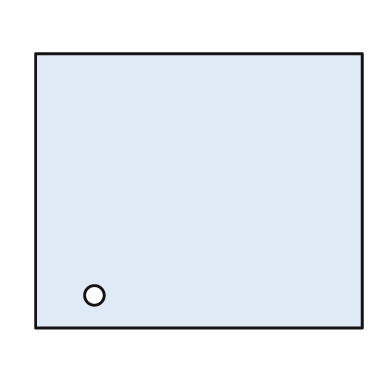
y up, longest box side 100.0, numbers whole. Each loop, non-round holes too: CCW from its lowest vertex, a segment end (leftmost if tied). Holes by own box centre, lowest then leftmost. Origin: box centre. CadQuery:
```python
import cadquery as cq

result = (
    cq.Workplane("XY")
    .moveTo(-50.0, -42.0)
    .lineTo(50.0, -42.0)
    .lineTo(50.0, 42.0)
    .lineTo(-50.0, 42.0)
    .close()
    .moveTo(-32.0, -32.0)
    .circle(3.0)
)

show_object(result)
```